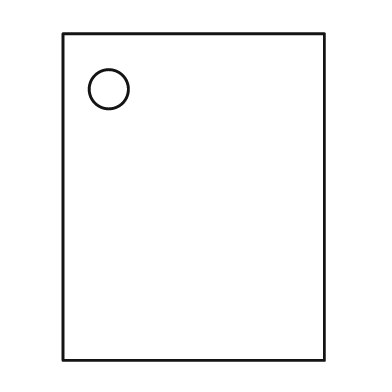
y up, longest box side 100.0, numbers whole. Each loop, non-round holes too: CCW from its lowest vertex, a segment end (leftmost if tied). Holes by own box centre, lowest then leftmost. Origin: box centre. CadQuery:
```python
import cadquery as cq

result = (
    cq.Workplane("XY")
    .moveTo(-40.0, -50.0)
    .lineTo(40.0, -50.0)
    .lineTo(40.0, 50.0)
    .lineTo(-40.0, 50.0)
    .close()
    .moveTo(-26.0, 33.0)
    .circle(6.0)
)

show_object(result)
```